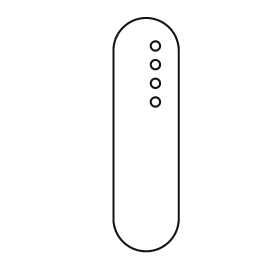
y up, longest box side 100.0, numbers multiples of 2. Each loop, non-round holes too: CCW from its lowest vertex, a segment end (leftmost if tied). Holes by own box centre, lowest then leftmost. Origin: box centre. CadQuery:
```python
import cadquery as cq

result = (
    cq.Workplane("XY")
    .moveTo(-14.0, -36.0)
    .threePointArc((0.0, -50.0), (14.0, -36.0))
    .lineTo(14.0, 36.0)
    .threePointArc((0.0, 50.0), (-14.0, 36.0))
    .close()
    .moveTo(4.0, 14.0)
    .circle(2.0)
    .moveTo(4.0, 22.0)
    .circle(2.0)
    .moveTo(4.0, 30.0)
    .circle(2.0)
    .moveTo(4.0, 38.0)
    .circle(2.0)
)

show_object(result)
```